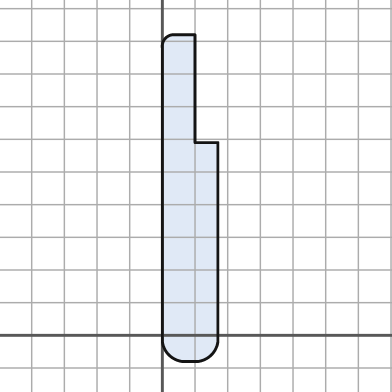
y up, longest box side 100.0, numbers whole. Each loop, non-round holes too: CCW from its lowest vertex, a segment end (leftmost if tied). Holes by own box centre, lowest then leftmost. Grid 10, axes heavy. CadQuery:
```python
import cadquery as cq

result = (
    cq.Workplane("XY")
    .moveTo(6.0, -8.0)
    .lineTo(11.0, -8.0)
    .threePointArc((15.0, -6.0), (17.0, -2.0))
    .lineTo(17.0, 59.0)
    .lineTo(10.0, 59.0)
    .lineTo(10.0, 92.0)
    .lineTo(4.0, 92.0)
    .threePointArc((1.0, 91.0), (0.0, 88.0))
    .lineTo(0.0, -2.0)
    .threePointArc((2.0, -6.0), (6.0, -8.0))
    .close()
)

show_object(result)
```